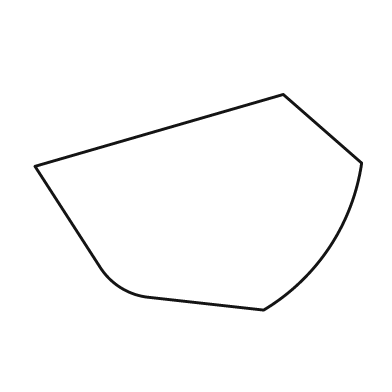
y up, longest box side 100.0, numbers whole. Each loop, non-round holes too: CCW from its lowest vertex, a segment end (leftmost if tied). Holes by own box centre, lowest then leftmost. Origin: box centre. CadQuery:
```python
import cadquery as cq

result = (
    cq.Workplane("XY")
    .moveTo(20.0, -33.0)
    .threePointArc((40.0, -14.0), (50.0, 12.0))
    .lineTo(26.0, 33.0)
    .lineTo(-50.0, 11.0)
    .lineTo(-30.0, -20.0)
    .threePointArc((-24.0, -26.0), (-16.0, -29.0))
    .close()
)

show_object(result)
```